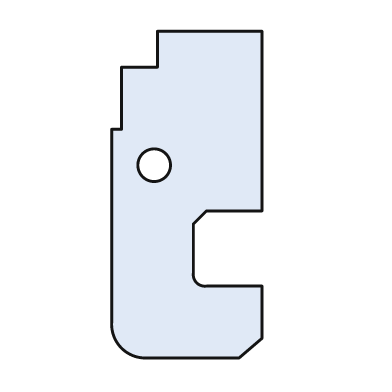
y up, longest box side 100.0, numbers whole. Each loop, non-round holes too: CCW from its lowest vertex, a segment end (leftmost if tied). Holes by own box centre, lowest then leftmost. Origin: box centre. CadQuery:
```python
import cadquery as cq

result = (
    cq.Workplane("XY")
    .moveTo(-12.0, -50.0)
    .lineTo(16.0, -50.0)
    .lineTo(23.0, -44.0)
    .lineTo(23.0, -28.0)
    .lineTo(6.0, -28.0)
    .threePointArc((3.0, -27.0), (2.0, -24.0))
    .lineTo(2.0, -9.0)
    .lineTo(6.0, -5.0)
    .lineTo(23.0, -5.0)
    .lineTo(23.0, 50.0)
    .lineTo(-9.0, 50.0)
    .lineTo(-9.0, 39.0)
    .lineTo(-20.0, 39.0)
    .lineTo(-20.0, 20.0)
    .lineTo(-23.0, 20.0)
    .lineTo(-23.0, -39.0)
    .threePointArc((-20.0, -47.0), (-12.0, -50.0))
    .close()
    .moveTo(-10.0, 9.0)
    .circle(5.0)
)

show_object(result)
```